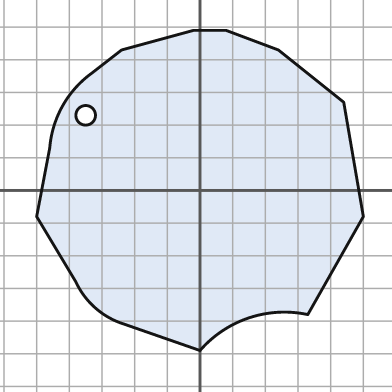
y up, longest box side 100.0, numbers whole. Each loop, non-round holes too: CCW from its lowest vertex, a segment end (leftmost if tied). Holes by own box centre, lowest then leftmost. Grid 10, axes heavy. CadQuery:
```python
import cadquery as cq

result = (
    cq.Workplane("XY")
    .moveTo(0.0, -49.0)
    .threePointArc((15.0, -39.0), (33.0, -38.0))
    .lineTo(50.0, -8.0)
    .lineTo(44.0, 27.0)
    .lineTo(24.0, 43.0)
    .lineTo(8.0, 49.0)
    .lineTo(-2.0, 49.0)
    .lineTo(-24.0, 43.0)
    .lineTo(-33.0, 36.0)
    .threePointArc((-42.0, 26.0), (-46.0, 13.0))
    .lineTo(-50.0, -8.0)
    .lineTo(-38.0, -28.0)
    .threePointArc((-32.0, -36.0), (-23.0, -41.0))
    .close()
    .moveTo(-35.0, 23.0)
    .circle(3.0)
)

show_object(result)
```